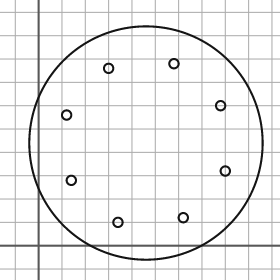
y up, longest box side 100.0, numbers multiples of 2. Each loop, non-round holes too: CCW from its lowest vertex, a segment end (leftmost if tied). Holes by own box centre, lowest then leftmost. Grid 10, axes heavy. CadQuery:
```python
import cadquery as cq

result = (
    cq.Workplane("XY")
    .moveTo(46.0, 44.0)
    .circle(50.0)
    .moveTo(34.0, 10.0)
    .circle(2.0)
    .moveTo(62.0, 12.0)
    .circle(2.0)
    .moveTo(14.0, 28.0)
    .circle(2.0)
    .moveTo(80.0, 32.0)
    .circle(2.0)
    .moveTo(12.0, 56.0)
    .circle(2.0)
    .moveTo(78.0, 60.0)
    .circle(2.0)
    .moveTo(30.0, 76.0)
    .circle(2.0)
    .moveTo(58.0, 78.0)
    .circle(2.0)
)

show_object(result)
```